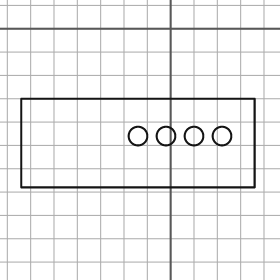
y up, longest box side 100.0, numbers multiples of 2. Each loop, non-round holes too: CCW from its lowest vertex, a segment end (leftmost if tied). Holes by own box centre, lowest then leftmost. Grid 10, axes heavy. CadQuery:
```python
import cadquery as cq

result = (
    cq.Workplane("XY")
    .moveTo(-64.0, -68.0)
    .lineTo(36.0, -68.0)
    .lineTo(36.0, -30.0)
    .lineTo(-64.0, -30.0)
    .close()
    .moveTo(-14.0, -46.0)
    .circle(4.0)
    .moveTo(-2.0, -46.0)
    .circle(4.0)
    .moveTo(10.0, -46.0)
    .circle(4.0)
    .moveTo(22.0, -46.0)
    .circle(4.0)
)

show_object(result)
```